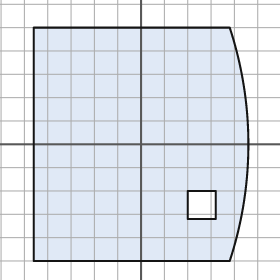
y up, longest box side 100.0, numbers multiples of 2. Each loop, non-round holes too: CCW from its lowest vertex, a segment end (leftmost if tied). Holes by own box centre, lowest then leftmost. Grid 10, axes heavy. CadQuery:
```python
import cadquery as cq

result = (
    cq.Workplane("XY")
    .moveTo(-46.0, -50.0)
    .lineTo(38.0, -50.0)
    .threePointArc((46.0, 0.0), (38.0, 50.0))
    .lineTo(-46.0, 50.0)
    .close()
    .moveTo(20.0, -32.0)
    .lineTo(32.0, -32.0)
    .lineTo(32.0, -20.0)
    .lineTo(20.0, -20.0)
    .close()
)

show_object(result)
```